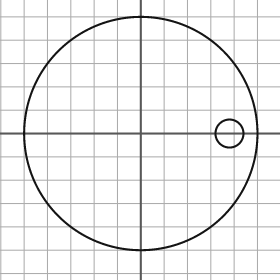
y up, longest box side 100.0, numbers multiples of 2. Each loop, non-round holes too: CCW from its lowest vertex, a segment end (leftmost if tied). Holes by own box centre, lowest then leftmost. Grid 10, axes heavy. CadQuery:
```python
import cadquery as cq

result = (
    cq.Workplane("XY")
    .moveTo(0.0, 0.0)
    .circle(50.0)
    .moveTo(38.0, 0.0)
    .circle(6.0)
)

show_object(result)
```